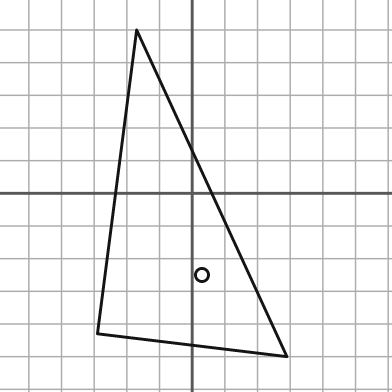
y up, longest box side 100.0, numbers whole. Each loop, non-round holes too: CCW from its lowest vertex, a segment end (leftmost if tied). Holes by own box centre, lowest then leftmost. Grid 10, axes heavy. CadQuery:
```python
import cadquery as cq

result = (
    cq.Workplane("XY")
    .moveTo(29.0, -50.0)
    .lineTo(-17.0, 50.0)
    .lineTo(-29.0, -43.0)
    .close()
    .moveTo(3.0, -25.0)
    .circle(2.0)
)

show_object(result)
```